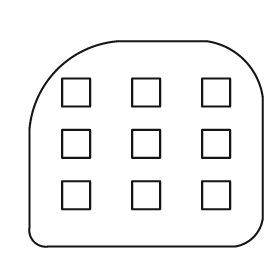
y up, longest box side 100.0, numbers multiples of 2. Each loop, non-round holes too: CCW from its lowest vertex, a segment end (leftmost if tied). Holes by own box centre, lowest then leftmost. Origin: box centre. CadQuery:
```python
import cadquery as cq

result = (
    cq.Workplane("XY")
    .moveTo(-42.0, -44.0)
    .lineTo(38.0, -44.0)
    .threePointArc((46.0, -40.0), (50.0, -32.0))
    .lineTo(50.0, 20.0)
    .threePointArc((42.0, 36.0), (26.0, 44.0))
    .lineTo(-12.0, 44.0)
    .threePointArc((-38.0, 32.0), (-50.0, 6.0))
    .lineTo(-50.0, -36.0)
    .threePointArc((-48.0, -42.0), (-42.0, -44.0))
    .close()
    .moveTo(-36.0, -28.0)
    .lineTo(-24.0, -28.0)
    .lineTo(-24.0, -16.0)
    .lineTo(-36.0, -16.0)
    .close()
    .moveTo(-6.0, -28.0)
    .lineTo(6.0, -28.0)
    .lineTo(6.0, -16.0)
    .lineTo(-6.0, -16.0)
    .close()
    .moveTo(24.0, -28.0)
    .lineTo(36.0, -28.0)
    .lineTo(36.0, -16.0)
    .lineTo(24.0, -16.0)
    .close()
    .moveTo(-36.0, -6.0)
    .lineTo(-24.0, -6.0)
    .lineTo(-24.0, 6.0)
    .lineTo(-36.0, 6.0)
    .close()
    .moveTo(-6.0, -6.0)
    .lineTo(6.0, -6.0)
    .lineTo(6.0, 6.0)
    .lineTo(-6.0, 6.0)
    .close()
    .moveTo(24.0, -6.0)
    .lineTo(36.0, -6.0)
    .lineTo(36.0, 6.0)
    .lineTo(24.0, 6.0)
    .close()
    .moveTo(-36.0, 16.0)
    .lineTo(-24.0, 16.0)
    .lineTo(-24.0, 28.0)
    .lineTo(-36.0, 28.0)
    .close()
    .moveTo(-6.0, 16.0)
    .lineTo(6.0, 16.0)
    .lineTo(6.0, 28.0)
    .lineTo(-6.0, 28.0)
    .close()
    .moveTo(24.0, 16.0)
    .lineTo(36.0, 16.0)
    .lineTo(36.0, 28.0)
    .lineTo(24.0, 28.0)
    .close()
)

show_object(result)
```